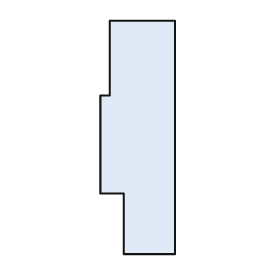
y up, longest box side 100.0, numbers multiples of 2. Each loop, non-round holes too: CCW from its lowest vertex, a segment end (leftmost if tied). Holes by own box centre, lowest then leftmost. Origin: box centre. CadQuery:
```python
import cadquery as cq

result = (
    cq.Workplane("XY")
    .moveTo(-6.0, -50.0)
    .lineTo(16.0, -50.0)
    .lineTo(16.0, 50.0)
    .lineTo(-12.0, 50.0)
    .lineTo(-12.0, 18.0)
    .lineTo(-16.0, 18.0)
    .lineTo(-16.0, -24.0)
    .lineTo(-6.0, -24.0)
    .close()
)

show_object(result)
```